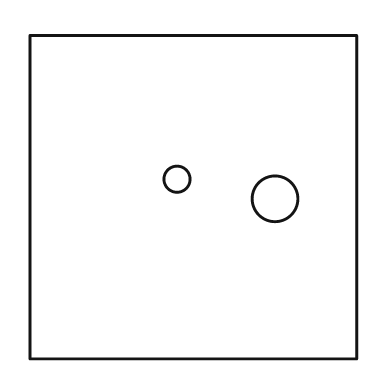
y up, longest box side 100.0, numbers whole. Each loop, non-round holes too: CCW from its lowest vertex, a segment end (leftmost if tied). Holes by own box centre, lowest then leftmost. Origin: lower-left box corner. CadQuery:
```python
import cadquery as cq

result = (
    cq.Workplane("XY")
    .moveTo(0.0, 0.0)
    .lineTo(100.0, 0.0)
    .lineTo(100.0, 99.0)
    .lineTo(0.0, 99.0)
    .close()
    .moveTo(75.0, 49.0)
    .circle(7.0)
    .moveTo(45.0, 55.0)
    .circle(4.0)
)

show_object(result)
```